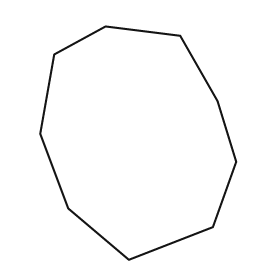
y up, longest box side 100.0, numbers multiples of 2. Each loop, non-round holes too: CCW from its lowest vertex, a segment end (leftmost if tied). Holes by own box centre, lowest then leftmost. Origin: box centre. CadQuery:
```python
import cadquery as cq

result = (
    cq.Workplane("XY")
    .moveTo(-4.0, -50.0)
    .lineTo(32.0, -36.0)
    .lineTo(42.0, -8.0)
    .lineTo(34.0, 18.0)
    .lineTo(18.0, 46.0)
    .lineTo(-14.0, 50.0)
    .lineTo(-36.0, 38.0)
    .lineTo(-42.0, 4.0)
    .lineTo(-30.0, -28.0)
    .close()
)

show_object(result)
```